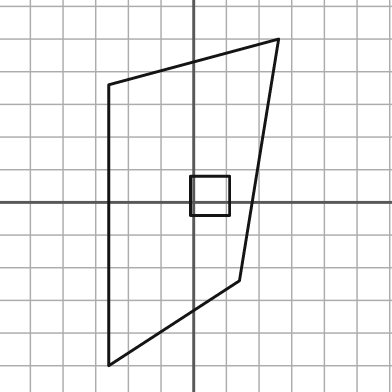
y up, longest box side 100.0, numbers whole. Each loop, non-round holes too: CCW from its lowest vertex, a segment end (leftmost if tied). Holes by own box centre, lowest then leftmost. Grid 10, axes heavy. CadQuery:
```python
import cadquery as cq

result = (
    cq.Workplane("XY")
    .moveTo(-26.0, -50.0)
    .lineTo(14.0, -24.0)
    .lineTo(26.0, 50.0)
    .lineTo(-26.0, 36.0)
    .close()
    .moveTo(-1.0, -4.0)
    .lineTo(11.0, -4.0)
    .lineTo(11.0, 8.0)
    .lineTo(-1.0, 8.0)
    .close()
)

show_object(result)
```